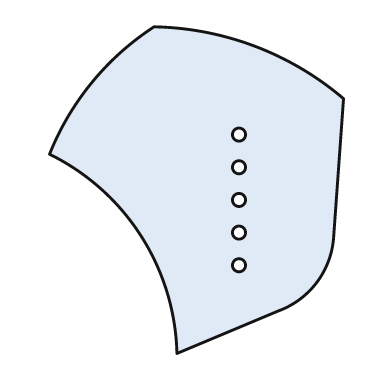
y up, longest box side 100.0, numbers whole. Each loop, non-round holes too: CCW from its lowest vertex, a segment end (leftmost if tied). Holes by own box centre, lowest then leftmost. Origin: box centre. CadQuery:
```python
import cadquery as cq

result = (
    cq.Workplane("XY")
    .moveTo(-6.0, -50.0)
    .lineTo(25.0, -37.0)
    .threePointArc((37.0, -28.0), (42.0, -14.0))
    .lineTo(45.0, 28.0)
    .threePointArc((18.0, 44.0), (-13.0, 50.0))
    .threePointArc((-32.0, 33.0), (-45.0, 11.0))
    .threePointArc((-17.0, -14.0), (-6.0, -50.0))
    .close()
    .moveTo(13.0, -23.0)
    .circle(2.0)
    .moveTo(13.0, -13.0)
    .circle(2.0)
    .moveTo(13.0, -3.0)
    .circle(2.0)
    .moveTo(13.0, 7.0)
    .circle(2.0)
    .moveTo(13.0, 17.0)
    .circle(2.0)
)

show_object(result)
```